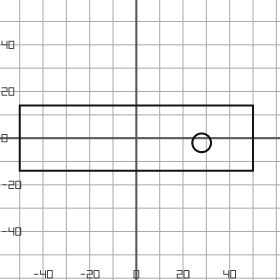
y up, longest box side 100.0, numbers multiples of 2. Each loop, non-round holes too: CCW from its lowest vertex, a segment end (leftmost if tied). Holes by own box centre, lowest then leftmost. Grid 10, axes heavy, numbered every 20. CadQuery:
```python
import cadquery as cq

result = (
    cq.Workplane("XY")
    .moveTo(-50.0, -14.0)
    .lineTo(50.0, -14.0)
    .lineTo(50.0, 14.0)
    .lineTo(-50.0, 14.0)
    .close()
    .moveTo(28.0, -2.0)
    .circle(4.0)
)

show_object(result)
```